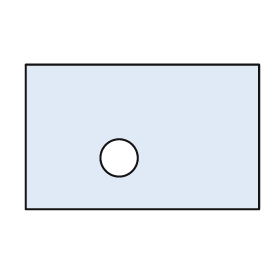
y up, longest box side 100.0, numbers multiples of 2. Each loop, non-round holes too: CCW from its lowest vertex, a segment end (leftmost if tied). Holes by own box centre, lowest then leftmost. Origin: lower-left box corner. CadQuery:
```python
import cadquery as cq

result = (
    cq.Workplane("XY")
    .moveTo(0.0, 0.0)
    .lineTo(100.0, 0.0)
    .lineTo(100.0, 62.0)
    .lineTo(0.0, 62.0)
    .close()
    .moveTo(40.0, 22.0)
    .circle(8.0)
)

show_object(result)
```